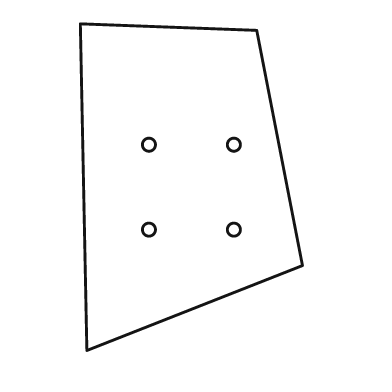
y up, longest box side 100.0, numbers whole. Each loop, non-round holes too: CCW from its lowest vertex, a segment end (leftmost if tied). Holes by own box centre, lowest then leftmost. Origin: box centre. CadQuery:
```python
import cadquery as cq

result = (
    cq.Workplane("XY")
    .moveTo(-32.0, -50.0)
    .lineTo(34.0, -24.0)
    .lineTo(20.0, 48.0)
    .lineTo(-34.0, 50.0)
    .close()
    .moveTo(-13.0, -13.0)
    .circle(2.0)
    .moveTo(13.0, -13.0)
    .circle(2.0)
    .moveTo(-13.0, 13.0)
    .circle(2.0)
    .moveTo(13.0, 13.0)
    .circle(2.0)
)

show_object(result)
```